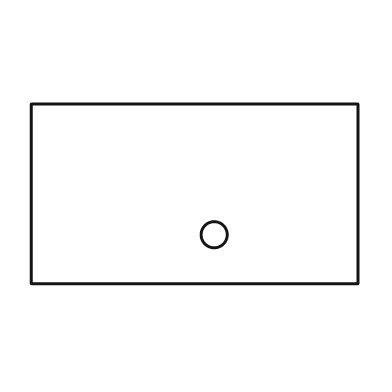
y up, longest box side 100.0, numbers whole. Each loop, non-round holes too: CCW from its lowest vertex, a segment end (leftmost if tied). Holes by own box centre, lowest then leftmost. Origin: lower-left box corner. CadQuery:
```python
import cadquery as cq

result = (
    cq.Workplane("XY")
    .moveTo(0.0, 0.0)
    .lineTo(100.0, 0.0)
    .lineTo(100.0, 55.0)
    .lineTo(0.0, 55.0)
    .close()
    .moveTo(56.0, 15.0)
    .circle(4.0)
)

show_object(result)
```